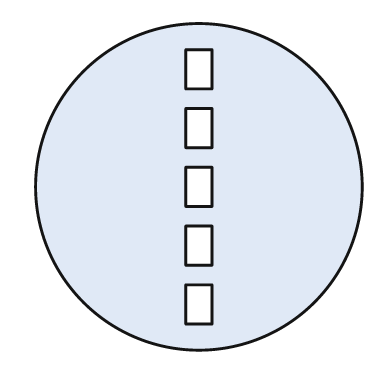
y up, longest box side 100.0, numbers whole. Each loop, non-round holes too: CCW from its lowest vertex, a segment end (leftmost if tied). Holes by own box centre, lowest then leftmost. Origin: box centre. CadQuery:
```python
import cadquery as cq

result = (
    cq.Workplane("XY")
    .moveTo(0.0, 0.0)
    .circle(50.0)
    .moveTo(-4.0, -42.0)
    .lineTo(4.0, -42.0)
    .lineTo(4.0, -30.0)
    .lineTo(-4.0, -30.0)
    .close()
    .moveTo(-4.0, -24.0)
    .lineTo(4.0, -24.0)
    .lineTo(4.0, -12.0)
    .lineTo(-4.0, -12.0)
    .close()
    .moveTo(-4.0, -6.0)
    .lineTo(4.0, -6.0)
    .lineTo(4.0, 6.0)
    .lineTo(-4.0, 6.0)
    .close()
    .moveTo(-4.0, 12.0)
    .lineTo(4.0, 12.0)
    .lineTo(4.0, 24.0)
    .lineTo(-4.0, 24.0)
    .close()
    .moveTo(-4.0, 30.0)
    .lineTo(4.0, 30.0)
    .lineTo(4.0, 42.0)
    .lineTo(-4.0, 42.0)
    .close()
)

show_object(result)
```